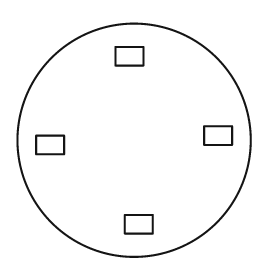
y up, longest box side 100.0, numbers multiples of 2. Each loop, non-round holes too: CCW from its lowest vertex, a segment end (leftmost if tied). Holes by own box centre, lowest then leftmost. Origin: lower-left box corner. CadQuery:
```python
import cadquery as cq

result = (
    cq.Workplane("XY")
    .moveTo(50.0, 50.0)
    .circle(50.0)
    .moveTo(46.0, 10.0)
    .lineTo(58.0, 10.0)
    .lineTo(58.0, 18.0)
    .lineTo(46.0, 18.0)
    .close()
    .moveTo(8.0, 44.0)
    .lineTo(20.0, 44.0)
    .lineTo(20.0, 52.0)
    .lineTo(8.0, 52.0)
    .close()
    .moveTo(80.0, 48.0)
    .lineTo(92.0, 48.0)
    .lineTo(92.0, 56.0)
    .lineTo(80.0, 56.0)
    .close()
    .moveTo(42.0, 82.0)
    .lineTo(54.0, 82.0)
    .lineTo(54.0, 90.0)
    .lineTo(42.0, 90.0)
    .close()
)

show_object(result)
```